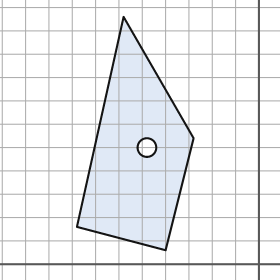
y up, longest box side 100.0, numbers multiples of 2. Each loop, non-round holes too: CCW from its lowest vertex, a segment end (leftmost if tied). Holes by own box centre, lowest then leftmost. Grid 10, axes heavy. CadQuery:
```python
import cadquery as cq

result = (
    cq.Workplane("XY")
    .moveTo(-40.0, 6.0)
    .lineTo(-28.0, 54.0)
    .lineTo(-58.0, 106.0)
    .lineTo(-78.0, 16.0)
    .close()
    .moveTo(-48.0, 50.0)
    .circle(4.0)
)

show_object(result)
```